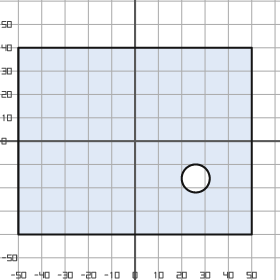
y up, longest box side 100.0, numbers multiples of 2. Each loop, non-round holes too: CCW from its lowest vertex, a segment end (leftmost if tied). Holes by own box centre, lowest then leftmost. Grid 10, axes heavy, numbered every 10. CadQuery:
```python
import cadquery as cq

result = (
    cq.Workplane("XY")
    .moveTo(-50.0, -40.0)
    .lineTo(50.0, -40.0)
    .lineTo(50.0, 40.0)
    .lineTo(-50.0, 40.0)
    .close()
    .moveTo(26.0, -16.0)
    .circle(6.0)
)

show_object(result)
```